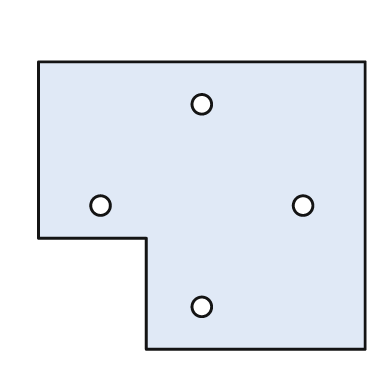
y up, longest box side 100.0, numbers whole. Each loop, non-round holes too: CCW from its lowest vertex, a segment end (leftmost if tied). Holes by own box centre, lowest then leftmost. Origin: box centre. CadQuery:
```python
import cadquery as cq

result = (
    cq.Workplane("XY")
    .moveTo(-17.0, -44.0)
    .lineTo(50.0, -44.0)
    .lineTo(50.0, 44.0)
    .lineTo(-50.0, 44.0)
    .lineTo(-50.0, -10.0)
    .lineTo(-17.0, -10.0)
    .close()
    .moveTo(0.0, -31.0)
    .circle(3.0)
    .moveTo(-31.0, 0.0)
    .circle(3.0)
    .moveTo(31.0, 0.0)
    .circle(3.0)
    .moveTo(0.0, 31.0)
    .circle(3.0)
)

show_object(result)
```